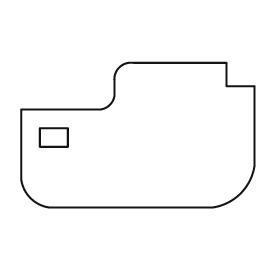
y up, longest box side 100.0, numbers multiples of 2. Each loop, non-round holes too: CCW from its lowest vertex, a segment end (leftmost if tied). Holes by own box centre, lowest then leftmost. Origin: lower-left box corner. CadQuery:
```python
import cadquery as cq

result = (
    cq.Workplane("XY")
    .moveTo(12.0, 0.0)
    .lineTo(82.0, 0.0)
    .threePointArc((94.0, 6.0), (100.0, 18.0))
    .lineTo(100.0, 52.0)
    .lineTo(88.0, 52.0)
    .lineTo(88.0, 62.0)
    .lineTo(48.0, 62.0)
    .threePointArc((42.0, 60.0), (40.0, 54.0))
    .lineTo(40.0, 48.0)
    .threePointArc((38.0, 44.0), (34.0, 42.0))
    .lineTo(0.0, 42.0)
    .lineTo(0.0, 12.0)
    .threePointArc((4.0, 4.0), (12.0, 0.0))
    .close()
    .moveTo(8.0, 26.0)
    .lineTo(20.0, 26.0)
    .lineTo(20.0, 34.0)
    .lineTo(8.0, 34.0)
    .close()
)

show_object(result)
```